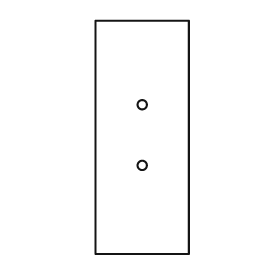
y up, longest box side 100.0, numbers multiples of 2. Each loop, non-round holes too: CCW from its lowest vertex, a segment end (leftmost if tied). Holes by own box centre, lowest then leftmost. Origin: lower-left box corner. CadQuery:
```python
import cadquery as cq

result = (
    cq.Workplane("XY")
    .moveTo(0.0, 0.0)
    .lineTo(40.0, 0.0)
    .lineTo(40.0, 100.0)
    .lineTo(0.0, 100.0)
    .close()
    .moveTo(20.0, 38.0)
    .circle(2.0)
    .moveTo(20.0, 64.0)
    .circle(2.0)
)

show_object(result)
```